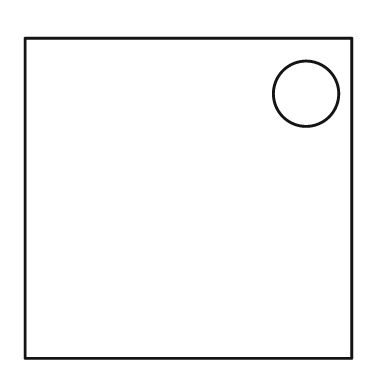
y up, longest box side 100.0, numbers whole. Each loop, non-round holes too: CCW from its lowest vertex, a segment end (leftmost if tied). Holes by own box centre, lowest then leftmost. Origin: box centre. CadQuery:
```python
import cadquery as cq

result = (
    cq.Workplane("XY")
    .moveTo(-50.0, -49.0)
    .lineTo(50.0, -49.0)
    .lineTo(50.0, 49.0)
    .lineTo(-50.0, 49.0)
    .close()
    .moveTo(36.0, 32.0)
    .circle(10.0)
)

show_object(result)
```